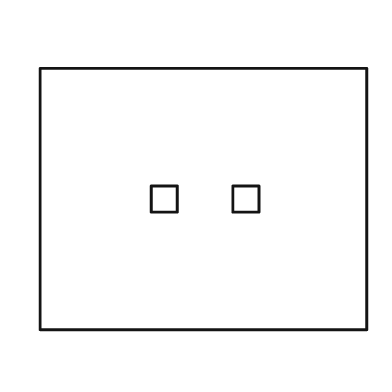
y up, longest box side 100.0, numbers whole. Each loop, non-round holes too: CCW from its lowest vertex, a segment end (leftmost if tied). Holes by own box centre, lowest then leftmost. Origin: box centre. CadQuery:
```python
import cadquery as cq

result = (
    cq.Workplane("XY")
    .moveTo(-50.0, -40.0)
    .lineTo(50.0, -40.0)
    .lineTo(50.0, 40.0)
    .lineTo(-50.0, 40.0)
    .close()
    .moveTo(-16.0, -4.0)
    .lineTo(-8.0, -4.0)
    .lineTo(-8.0, 4.0)
    .lineTo(-16.0, 4.0)
    .close()
    .moveTo(9.0, -4.0)
    .lineTo(17.0, -4.0)
    .lineTo(17.0, 4.0)
    .lineTo(9.0, 4.0)
    .close()
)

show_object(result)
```